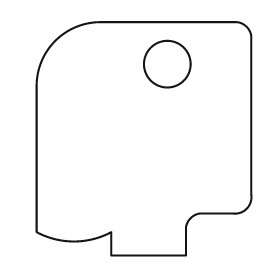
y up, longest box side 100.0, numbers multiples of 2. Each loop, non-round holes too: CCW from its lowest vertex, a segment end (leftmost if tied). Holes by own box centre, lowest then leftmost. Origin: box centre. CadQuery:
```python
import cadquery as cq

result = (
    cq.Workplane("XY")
    .moveTo(-14.0, -50.0)
    .lineTo(18.0, -50.0)
    .lineTo(18.0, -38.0)
    .threePointArc((20.0, -34.0), (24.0, -32.0))
    .lineTo(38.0, -32.0)
    .threePointArc((44.0, -30.0), (46.0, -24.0))
    .lineTo(46.0, 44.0)
    .threePointArc((44.0, 48.0), (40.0, 50.0))
    .lineTo(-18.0, 50.0)
    .threePointArc((-38.0, 42.0), (-46.0, 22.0))
    .lineTo(-46.0, -40.0)
    .threePointArc((-30.0, -44.0), (-14.0, -40.0))
    .close()
    .moveTo(10.0, 32.0)
    .circle(10.0)
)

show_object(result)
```